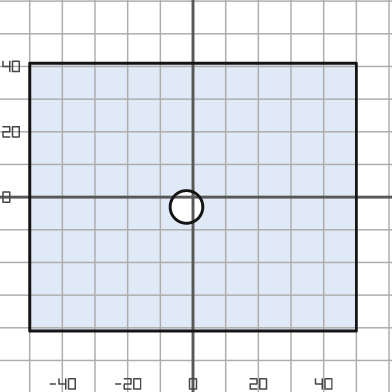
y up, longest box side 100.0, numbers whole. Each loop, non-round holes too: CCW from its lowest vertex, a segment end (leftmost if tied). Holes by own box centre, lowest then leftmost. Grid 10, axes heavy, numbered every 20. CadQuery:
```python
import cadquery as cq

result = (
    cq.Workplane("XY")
    .moveTo(-50.0, -41.0)
    .lineTo(50.0, -41.0)
    .lineTo(50.0, 41.0)
    .lineTo(-50.0, 41.0)
    .close()
    .moveTo(-2.0, -3.0)
    .circle(5.0)
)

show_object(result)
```